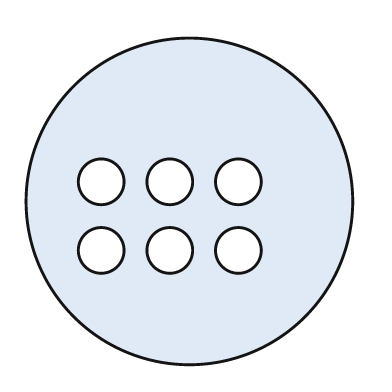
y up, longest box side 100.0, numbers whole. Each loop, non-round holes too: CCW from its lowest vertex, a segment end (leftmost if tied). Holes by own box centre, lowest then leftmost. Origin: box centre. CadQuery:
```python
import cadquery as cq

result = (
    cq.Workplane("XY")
    .moveTo(0.0, 0.0)
    .circle(50.0)
    .moveTo(-27.0, -15.0)
    .circle(7.0)
    .moveTo(-6.0, -15.0)
    .circle(7.0)
    .moveTo(15.0, -15.0)
    .circle(7.0)
    .moveTo(-27.0, 6.0)
    .circle(7.0)
    .moveTo(-6.0, 6.0)
    .circle(7.0)
    .moveTo(15.0, 6.0)
    .circle(7.0)
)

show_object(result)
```